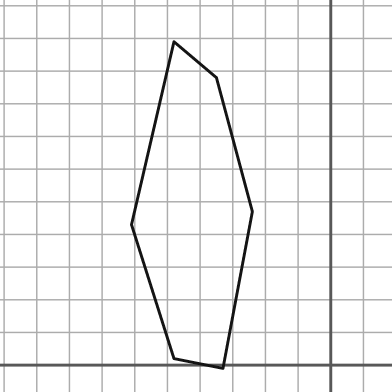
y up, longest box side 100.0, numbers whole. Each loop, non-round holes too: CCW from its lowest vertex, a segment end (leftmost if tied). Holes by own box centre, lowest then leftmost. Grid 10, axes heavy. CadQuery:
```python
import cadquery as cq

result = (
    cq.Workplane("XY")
    .moveTo(-33.0, -1.0)
    .lineTo(-24.0, 47.0)
    .lineTo(-35.0, 88.0)
    .lineTo(-48.0, 99.0)
    .lineTo(-61.0, 43.0)
    .lineTo(-48.0, 2.0)
    .close()
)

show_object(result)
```